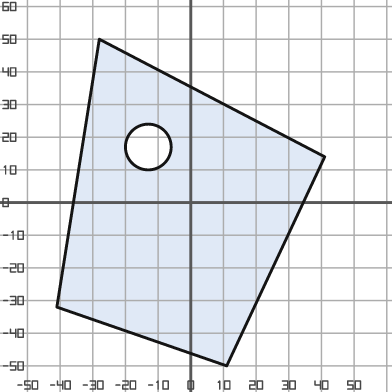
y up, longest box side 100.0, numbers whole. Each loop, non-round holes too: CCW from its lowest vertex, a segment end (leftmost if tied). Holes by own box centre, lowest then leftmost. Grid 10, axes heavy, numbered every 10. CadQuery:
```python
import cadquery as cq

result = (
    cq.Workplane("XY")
    .moveTo(11.0, -50.0)
    .lineTo(41.0, 14.0)
    .lineTo(-28.0, 50.0)
    .lineTo(-41.0, -32.0)
    .close()
    .moveTo(-13.0, 17.0)
    .circle(7.0)
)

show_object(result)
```